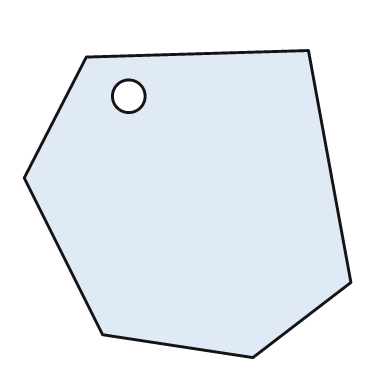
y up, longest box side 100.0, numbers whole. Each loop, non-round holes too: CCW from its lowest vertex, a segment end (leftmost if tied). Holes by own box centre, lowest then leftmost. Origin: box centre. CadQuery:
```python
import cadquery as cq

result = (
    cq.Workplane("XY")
    .moveTo(20.0, -47.0)
    .lineTo(50.0, -24.0)
    .lineTo(37.0, 47.0)
    .lineTo(-31.0, 45.0)
    .lineTo(-50.0, 8.0)
    .lineTo(-26.0, -40.0)
    .close()
    .moveTo(-18.0, 33.0)
    .circle(5.0)
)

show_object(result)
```